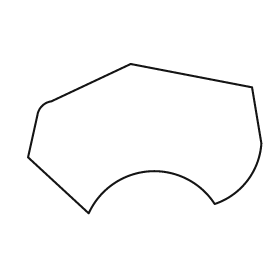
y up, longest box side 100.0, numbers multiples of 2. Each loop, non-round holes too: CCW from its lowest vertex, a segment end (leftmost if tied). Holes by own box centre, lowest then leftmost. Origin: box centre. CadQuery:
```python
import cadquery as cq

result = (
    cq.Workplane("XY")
    .moveTo(-24.0, -32.0)
    .threePointArc((2.0, -14.0), (30.0, -28.0))
    .threePointArc((44.0, -18.0), (50.0, -2.0))
    .lineTo(46.0, 22.0)
    .lineTo(-6.0, 32.0)
    .lineTo(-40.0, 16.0)
    .threePointArc((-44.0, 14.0), (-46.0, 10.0))
    .lineTo(-50.0, -8.0)
    .close()
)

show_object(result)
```